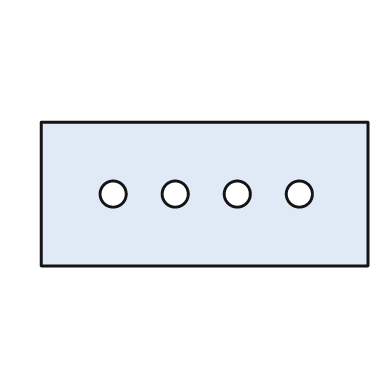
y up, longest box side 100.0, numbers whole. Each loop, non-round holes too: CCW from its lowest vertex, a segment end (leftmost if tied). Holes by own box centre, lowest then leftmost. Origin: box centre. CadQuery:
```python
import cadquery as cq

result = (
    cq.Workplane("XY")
    .moveTo(-50.0, -22.0)
    .lineTo(50.0, -22.0)
    .lineTo(50.0, 22.0)
    .lineTo(-50.0, 22.0)
    .close()
    .moveTo(-28.0, 0.0)
    .circle(4.0)
    .moveTo(-9.0, 0.0)
    .circle(4.0)
    .moveTo(10.0, 0.0)
    .circle(4.0)
    .moveTo(29.0, 0.0)
    .circle(4.0)
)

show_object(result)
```